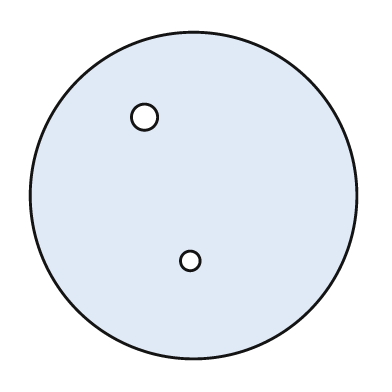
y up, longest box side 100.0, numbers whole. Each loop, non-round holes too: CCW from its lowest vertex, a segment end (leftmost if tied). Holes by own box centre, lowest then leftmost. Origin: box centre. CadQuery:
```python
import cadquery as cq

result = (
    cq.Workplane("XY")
    .moveTo(0.0, 0.0)
    .circle(50.0)
    .moveTo(-1.0, -20.0)
    .circle(3.0)
    .moveTo(-15.0, 24.0)
    .circle(4.0)
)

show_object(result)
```